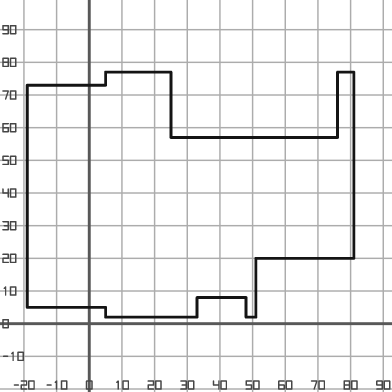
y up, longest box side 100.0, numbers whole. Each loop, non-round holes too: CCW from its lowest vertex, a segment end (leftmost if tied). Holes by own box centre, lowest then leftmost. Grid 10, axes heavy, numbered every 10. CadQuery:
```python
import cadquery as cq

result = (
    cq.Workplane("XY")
    .moveTo(5.0, 2.0)
    .lineTo(33.0, 2.0)
    .lineTo(33.0, 8.0)
    .lineTo(48.0, 8.0)
    .lineTo(48.0, 2.0)
    .lineTo(51.0, 2.0)
    .lineTo(51.0, 20.0)
    .lineTo(81.0, 20.0)
    .lineTo(81.0, 77.0)
    .lineTo(76.0, 77.0)
    .lineTo(76.0, 57.0)
    .lineTo(25.0, 57.0)
    .lineTo(25.0, 77.0)
    .lineTo(5.0, 77.0)
    .lineTo(5.0, 73.0)
    .lineTo(-19.0, 73.0)
    .lineTo(-19.0, 5.0)
    .lineTo(5.0, 5.0)
    .close()
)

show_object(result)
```